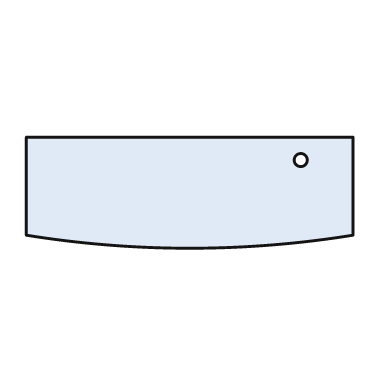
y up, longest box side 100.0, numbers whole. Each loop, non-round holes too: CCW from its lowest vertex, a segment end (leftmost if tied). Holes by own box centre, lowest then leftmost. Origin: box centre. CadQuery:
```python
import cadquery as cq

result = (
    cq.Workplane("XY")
    .moveTo(-50.0, -13.0)
    .threePointArc((0.0, -17.0), (50.0, -13.0))
    .lineTo(50.0, 17.0)
    .lineTo(-50.0, 17.0)
    .close()
    .moveTo(34.0, 10.0)
    .circle(2.0)
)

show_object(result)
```